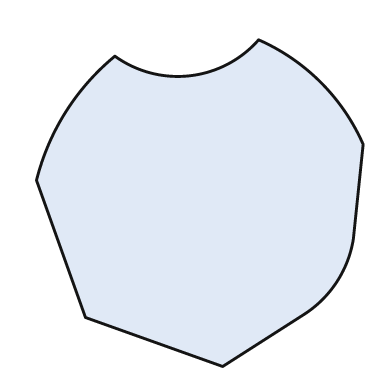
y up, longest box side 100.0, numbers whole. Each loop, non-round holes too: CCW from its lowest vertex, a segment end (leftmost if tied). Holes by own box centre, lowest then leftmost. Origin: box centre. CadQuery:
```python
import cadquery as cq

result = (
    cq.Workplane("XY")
    .moveTo(7.0, -50.0)
    .lineTo(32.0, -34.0)
    .threePointArc((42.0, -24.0), (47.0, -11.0))
    .lineTo(50.0, 18.0)
    .threePointArc((37.0, 37.0), (18.0, 50.0))
    .threePointArc((-3.0, 39.0), (-26.0, 45.0))
    .threePointArc((-41.0, 28.0), (-50.0, 7.0))
    .lineTo(-35.0, -35.0)
    .close()
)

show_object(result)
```